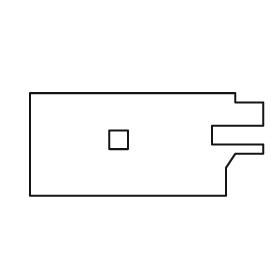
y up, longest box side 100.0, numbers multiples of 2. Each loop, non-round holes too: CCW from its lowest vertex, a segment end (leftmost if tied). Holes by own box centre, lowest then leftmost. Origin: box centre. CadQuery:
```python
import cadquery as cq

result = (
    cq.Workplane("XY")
    .moveTo(-50.0, -22.0)
    .lineTo(34.0, -22.0)
    .lineTo(34.0, -10.0)
    .lineTo(38.0, -4.0)
    .lineTo(50.0, -4.0)
    .lineTo(50.0, 0.0)
    .lineTo(28.0, 0.0)
    .lineTo(28.0, 8.0)
    .lineTo(50.0, 8.0)
    .lineTo(50.0, 18.0)
    .lineTo(38.0, 18.0)
    .lineTo(38.0, 22.0)
    .lineTo(-50.0, 22.0)
    .close()
    .moveTo(-16.0, -2.0)
    .lineTo(-8.0, -2.0)
    .lineTo(-8.0, 6.0)
    .lineTo(-16.0, 6.0)
    .close()
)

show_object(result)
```